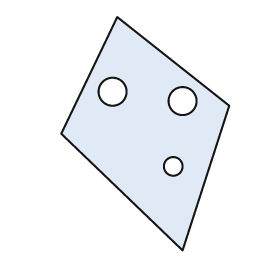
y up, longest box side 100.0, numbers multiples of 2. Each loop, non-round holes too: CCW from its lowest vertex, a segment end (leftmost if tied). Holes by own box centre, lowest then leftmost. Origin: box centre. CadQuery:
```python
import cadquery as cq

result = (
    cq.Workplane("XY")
    .moveTo(16.0, -50.0)
    .lineTo(36.0, 12.0)
    .lineTo(-12.0, 50.0)
    .lineTo(-36.0, 0.0)
    .close()
    .moveTo(12.0, -14.0)
    .circle(4.0)
    .moveTo(16.0, 14.0)
    .circle(6.0)
    .moveTo(-14.0, 18.0)
    .circle(6.0)
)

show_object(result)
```